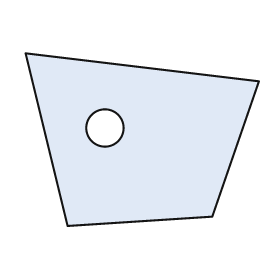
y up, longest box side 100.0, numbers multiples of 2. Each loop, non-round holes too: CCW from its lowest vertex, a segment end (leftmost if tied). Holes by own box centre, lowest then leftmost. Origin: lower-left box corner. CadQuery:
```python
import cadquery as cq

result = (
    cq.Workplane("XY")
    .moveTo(18.0, 0.0)
    .lineTo(80.0, 4.0)
    .lineTo(100.0, 62.0)
    .lineTo(0.0, 74.0)
    .close()
    .moveTo(34.0, 42.0)
    .circle(8.0)
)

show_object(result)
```